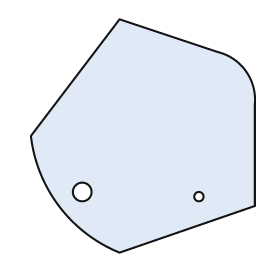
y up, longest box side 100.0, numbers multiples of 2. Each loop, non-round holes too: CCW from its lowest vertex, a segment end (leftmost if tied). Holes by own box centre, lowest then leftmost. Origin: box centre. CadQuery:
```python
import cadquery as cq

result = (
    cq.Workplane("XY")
    .moveTo(-10.0, -50.0)
    .lineTo(48.0, -30.0)
    .lineTo(48.0, 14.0)
    .threePointArc((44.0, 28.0), (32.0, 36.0))
    .lineTo(-10.0, 50.0)
    .lineTo(-48.0, 0.0)
    .threePointArc((-36.0, -30.0), (-10.0, -50.0))
    .close()
    .moveTo(24.0, -26.0)
    .circle(2.0)
    .moveTo(-26.0, -24.0)
    .circle(4.0)
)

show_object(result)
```